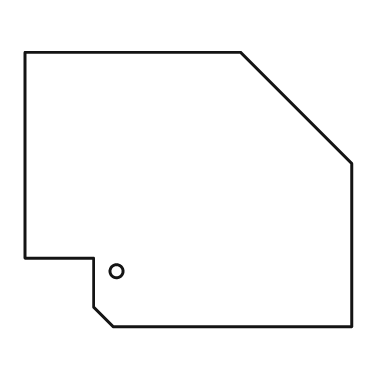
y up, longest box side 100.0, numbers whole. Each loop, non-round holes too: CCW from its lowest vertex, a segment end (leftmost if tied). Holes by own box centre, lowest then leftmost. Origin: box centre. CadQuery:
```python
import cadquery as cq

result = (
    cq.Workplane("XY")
    .moveTo(-23.0, -42.0)
    .lineTo(50.0, -42.0)
    .lineTo(50.0, 8.0)
    .lineTo(16.0, 42.0)
    .lineTo(-50.0, 42.0)
    .lineTo(-50.0, -21.0)
    .lineTo(-29.0, -21.0)
    .lineTo(-29.0, -36.0)
    .close()
    .moveTo(-22.0, -25.0)
    .circle(2.0)
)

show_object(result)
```